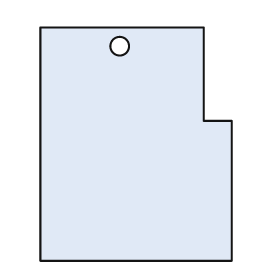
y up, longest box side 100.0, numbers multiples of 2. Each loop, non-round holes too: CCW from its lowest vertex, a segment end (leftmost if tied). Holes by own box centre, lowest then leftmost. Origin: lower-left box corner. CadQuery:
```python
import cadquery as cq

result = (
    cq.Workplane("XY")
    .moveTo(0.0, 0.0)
    .lineTo(82.0, 0.0)
    .lineTo(82.0, 60.0)
    .lineTo(70.0, 60.0)
    .lineTo(70.0, 100.0)
    .lineTo(0.0, 100.0)
    .close()
    .moveTo(34.0, 92.0)
    .circle(4.0)
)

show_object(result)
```